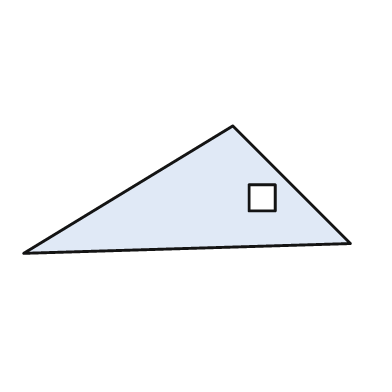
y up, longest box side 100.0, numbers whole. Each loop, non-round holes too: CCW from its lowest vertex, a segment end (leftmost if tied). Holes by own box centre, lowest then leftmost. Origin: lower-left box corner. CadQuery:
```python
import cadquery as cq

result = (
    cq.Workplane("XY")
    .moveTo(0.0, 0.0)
    .lineTo(100.0, 3.0)
    .lineTo(64.0, 39.0)
    .close()
    .moveTo(69.0, 13.0)
    .lineTo(77.0, 13.0)
    .lineTo(77.0, 21.0)
    .lineTo(69.0, 21.0)
    .close()
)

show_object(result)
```